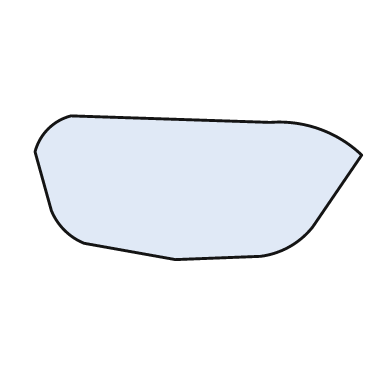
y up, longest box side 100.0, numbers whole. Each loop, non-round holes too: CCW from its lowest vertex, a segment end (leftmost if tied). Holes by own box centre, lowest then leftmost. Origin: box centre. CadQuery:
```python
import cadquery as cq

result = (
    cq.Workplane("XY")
    .moveTo(-7.0, -22.0)
    .lineTo(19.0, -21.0)
    .threePointArc((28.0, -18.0), (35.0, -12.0))
    .lineTo(50.0, 10.0)
    .threePointArc((37.0, 18.0), (22.0, 20.0))
    .lineTo(-39.0, 22.0)
    .threePointArc((-46.0, 18.0), (-50.0, 11.0))
    .lineTo(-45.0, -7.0)
    .threePointArc((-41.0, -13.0), (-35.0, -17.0))
    .close()
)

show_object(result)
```